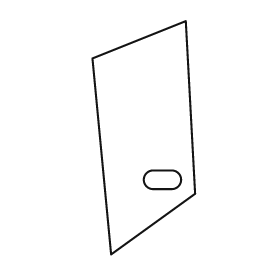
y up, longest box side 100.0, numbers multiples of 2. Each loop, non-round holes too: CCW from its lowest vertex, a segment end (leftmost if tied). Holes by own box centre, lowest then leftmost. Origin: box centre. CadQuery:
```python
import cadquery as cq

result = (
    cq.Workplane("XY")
    .moveTo(-14.0, -50.0)
    .lineTo(22.0, -24.0)
    .lineTo(18.0, 50.0)
    .lineTo(-22.0, 34.0)
    .close()
    .moveTo(4.0, -22.0)
    .lineTo(12.0, -22.0)
    .threePointArc((16.0, -18.0), (12.0, -14.0))
    .lineTo(4.0, -14.0)
    .threePointArc((0.0, -18.0), (4.0, -22.0))
    .close()
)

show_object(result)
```